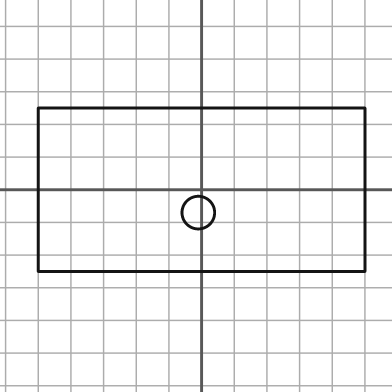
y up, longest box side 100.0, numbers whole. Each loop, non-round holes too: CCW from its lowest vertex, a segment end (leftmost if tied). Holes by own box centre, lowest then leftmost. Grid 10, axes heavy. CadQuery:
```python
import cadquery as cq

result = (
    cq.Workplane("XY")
    .moveTo(-50.0, -25.0)
    .lineTo(50.0, -25.0)
    .lineTo(50.0, 25.0)
    .lineTo(-50.0, 25.0)
    .close()
    .moveTo(-1.0, -7.0)
    .circle(5.0)
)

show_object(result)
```